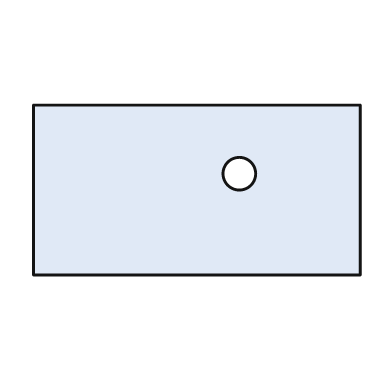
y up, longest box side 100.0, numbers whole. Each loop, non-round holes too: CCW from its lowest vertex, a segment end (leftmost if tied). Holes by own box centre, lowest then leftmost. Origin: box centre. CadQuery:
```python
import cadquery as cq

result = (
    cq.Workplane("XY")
    .moveTo(-50.0, -26.0)
    .lineTo(50.0, -26.0)
    .lineTo(50.0, 26.0)
    .lineTo(-50.0, 26.0)
    .close()
    .moveTo(13.0, 5.0)
    .circle(5.0)
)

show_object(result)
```